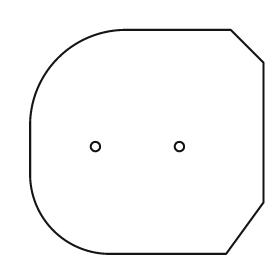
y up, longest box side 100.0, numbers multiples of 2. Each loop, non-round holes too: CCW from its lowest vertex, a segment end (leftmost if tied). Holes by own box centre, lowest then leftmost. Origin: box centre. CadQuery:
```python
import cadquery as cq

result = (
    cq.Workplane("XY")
    .moveTo(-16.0, -48.0)
    .lineTo(34.0, -48.0)
    .lineTo(50.0, -26.0)
    .lineTo(50.0, 34.0)
    .lineTo(36.0, 48.0)
    .lineTo(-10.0, 48.0)
    .threePointArc((-38.0, 36.0), (-50.0, 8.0))
    .lineTo(-50.0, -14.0)
    .threePointArc((-40.0, -38.0), (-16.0, -48.0))
    .close()
    .moveTo(-22.0, -2.0)
    .circle(2.0)
    .moveTo(14.0, -2.0)
    .circle(2.0)
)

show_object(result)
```